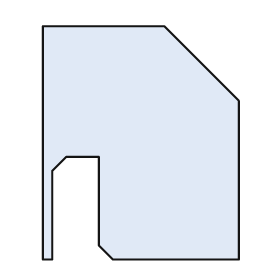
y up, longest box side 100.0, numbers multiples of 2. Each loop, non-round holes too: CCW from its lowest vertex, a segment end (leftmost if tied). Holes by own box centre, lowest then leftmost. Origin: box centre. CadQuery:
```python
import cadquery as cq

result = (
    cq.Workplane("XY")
    .moveTo(-42.0, -50.0)
    .lineTo(-38.0, -50.0)
    .lineTo(-38.0, -12.0)
    .lineTo(-32.0, -6.0)
    .lineTo(-18.0, -6.0)
    .lineTo(-18.0, -44.0)
    .lineTo(-12.0, -50.0)
    .lineTo(42.0, -50.0)
    .lineTo(42.0, 18.0)
    .lineTo(10.0, 50.0)
    .lineTo(-42.0, 50.0)
    .close()
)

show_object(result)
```